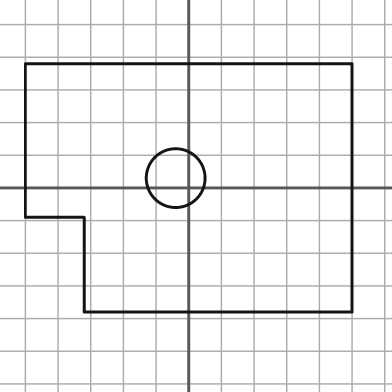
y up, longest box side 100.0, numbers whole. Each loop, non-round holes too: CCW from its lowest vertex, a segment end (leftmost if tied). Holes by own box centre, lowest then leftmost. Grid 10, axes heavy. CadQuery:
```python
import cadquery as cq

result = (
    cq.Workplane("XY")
    .moveTo(-32.0, -38.0)
    .lineTo(50.0, -38.0)
    .lineTo(50.0, 38.0)
    .lineTo(-50.0, 38.0)
    .lineTo(-50.0, -9.0)
    .lineTo(-32.0, -9.0)
    .close()
    .moveTo(-4.0, 3.0)
    .circle(9.0)
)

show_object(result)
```